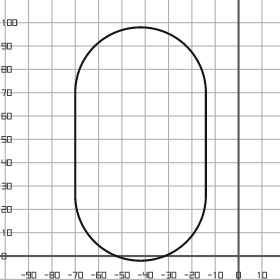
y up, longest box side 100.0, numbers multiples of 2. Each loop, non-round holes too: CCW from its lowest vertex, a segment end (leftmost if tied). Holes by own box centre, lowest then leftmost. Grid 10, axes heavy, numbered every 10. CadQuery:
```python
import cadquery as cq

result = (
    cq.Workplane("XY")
    .moveTo(-70.0, 26.0)
    .threePointArc((-42.0, -2.0), (-14.0, 26.0))
    .lineTo(-14.0, 70.0)
    .threePointArc((-42.0, 98.0), (-70.0, 70.0))
    .close()
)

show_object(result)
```